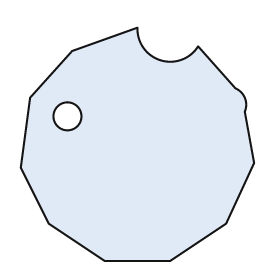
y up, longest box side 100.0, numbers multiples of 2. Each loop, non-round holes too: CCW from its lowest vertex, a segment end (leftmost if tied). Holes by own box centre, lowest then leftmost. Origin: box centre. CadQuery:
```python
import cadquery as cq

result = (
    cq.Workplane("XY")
    .moveTo(-14.0, -50.0)
    .lineTo(14.0, -50.0)
    .lineTo(38.0, -34.0)
    .lineTo(50.0, -8.0)
    .lineTo(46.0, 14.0)
    .threePointArc((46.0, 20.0), (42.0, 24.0))
    .lineTo(26.0, 42.0)
    .threePointArc((10.0, 36.0), (0.0, 50.0))
    .lineTo(-28.0, 40.0)
    .lineTo(-46.0, 20.0)
    .lineTo(-50.0, -10.0)
    .lineTo(-38.0, -34.0)
    .close()
    .moveTo(-30.0, 12.0)
    .circle(6.0)
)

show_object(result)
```